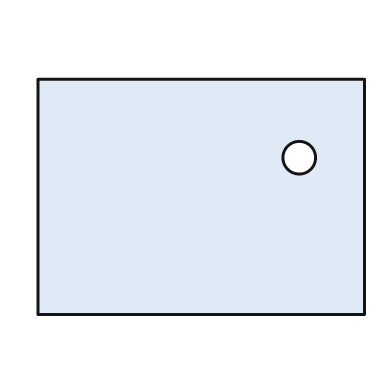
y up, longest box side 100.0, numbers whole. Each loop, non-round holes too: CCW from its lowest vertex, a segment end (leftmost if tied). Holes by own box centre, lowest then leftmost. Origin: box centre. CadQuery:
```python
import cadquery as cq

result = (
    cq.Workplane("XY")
    .moveTo(-50.0, -36.0)
    .lineTo(50.0, -36.0)
    .lineTo(50.0, 36.0)
    .lineTo(-50.0, 36.0)
    .close()
    .moveTo(30.0, 12.0)
    .circle(5.0)
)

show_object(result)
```